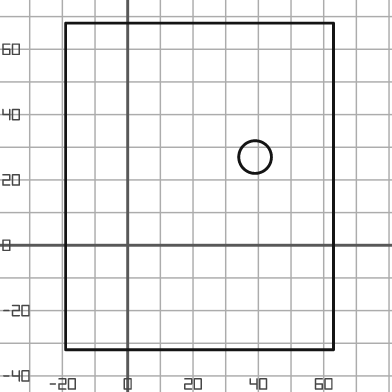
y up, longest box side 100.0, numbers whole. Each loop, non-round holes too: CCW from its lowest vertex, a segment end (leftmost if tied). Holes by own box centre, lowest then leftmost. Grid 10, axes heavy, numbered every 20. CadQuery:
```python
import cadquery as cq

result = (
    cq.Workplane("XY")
    .moveTo(-19.0, -32.0)
    .lineTo(63.0, -32.0)
    .lineTo(63.0, 68.0)
    .lineTo(-19.0, 68.0)
    .close()
    .moveTo(39.0, 27.0)
    .circle(5.0)
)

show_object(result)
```